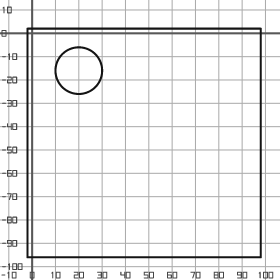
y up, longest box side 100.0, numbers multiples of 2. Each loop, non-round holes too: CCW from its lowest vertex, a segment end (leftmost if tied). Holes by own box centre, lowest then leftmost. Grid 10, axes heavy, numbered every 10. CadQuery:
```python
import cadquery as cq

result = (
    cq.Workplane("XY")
    .moveTo(-2.0, -96.0)
    .lineTo(98.0, -96.0)
    .lineTo(98.0, 2.0)
    .lineTo(-2.0, 2.0)
    .close()
    .moveTo(20.0, -16.0)
    .circle(10.0)
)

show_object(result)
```